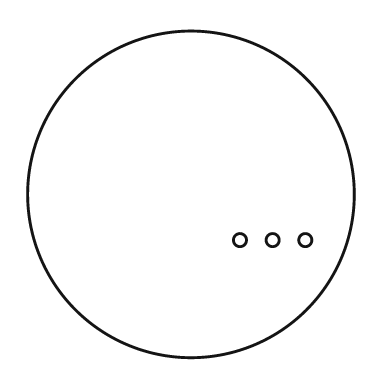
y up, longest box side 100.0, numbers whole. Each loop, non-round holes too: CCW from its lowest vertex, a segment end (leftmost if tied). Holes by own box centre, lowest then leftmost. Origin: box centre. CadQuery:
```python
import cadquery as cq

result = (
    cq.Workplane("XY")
    .moveTo(0.0, 0.0)
    .circle(50.0)
    .moveTo(15.0, -14.0)
    .circle(2.0)
    .moveTo(25.0, -14.0)
    .circle(2.0)
    .moveTo(35.0, -14.0)
    .circle(2.0)
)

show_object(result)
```